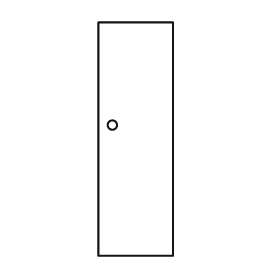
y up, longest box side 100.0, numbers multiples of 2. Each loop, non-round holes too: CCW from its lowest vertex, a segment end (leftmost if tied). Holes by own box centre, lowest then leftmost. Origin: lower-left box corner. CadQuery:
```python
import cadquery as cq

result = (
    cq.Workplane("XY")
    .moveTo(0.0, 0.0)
    .lineTo(32.0, 0.0)
    .lineTo(32.0, 100.0)
    .lineTo(0.0, 100.0)
    .close()
    .moveTo(6.0, 56.0)
    .circle(2.0)
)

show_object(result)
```